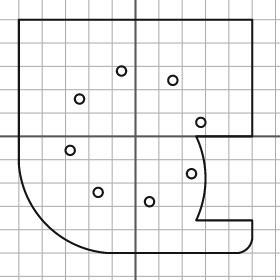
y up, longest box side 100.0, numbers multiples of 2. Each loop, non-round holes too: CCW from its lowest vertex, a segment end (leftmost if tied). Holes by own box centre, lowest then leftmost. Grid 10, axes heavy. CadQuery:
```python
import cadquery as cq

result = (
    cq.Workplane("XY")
    .moveTo(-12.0, -50.0)
    .lineTo(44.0, -50.0)
    .threePointArc((48.0, -48.0), (50.0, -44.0))
    .lineTo(50.0, -36.0)
    .lineTo(26.0, -36.0)
    .threePointArc((30.0, -18.0), (26.0, 0.0))
    .lineTo(50.0, 0.0)
    .lineTo(50.0, 50.0)
    .lineTo(-50.0, 50.0)
    .lineTo(-50.0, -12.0)
    .threePointArc((-38.0, -38.0), (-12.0, -50.0))
    .close()
    .moveTo(6.0, -28.0)
    .circle(2.0)
    .moveTo(-16.0, -24.0)
    .circle(2.0)
    .moveTo(24.0, -16.0)
    .circle(2.0)
    .moveTo(-28.0, -6.0)
    .circle(2.0)
    .moveTo(28.0, 6.0)
    .circle(2.0)
    .moveTo(-24.0, 16.0)
    .circle(2.0)
    .moveTo(16.0, 24.0)
    .circle(2.0)
    .moveTo(-6.0, 28.0)
    .circle(2.0)
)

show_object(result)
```